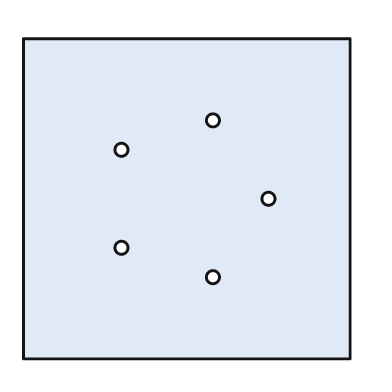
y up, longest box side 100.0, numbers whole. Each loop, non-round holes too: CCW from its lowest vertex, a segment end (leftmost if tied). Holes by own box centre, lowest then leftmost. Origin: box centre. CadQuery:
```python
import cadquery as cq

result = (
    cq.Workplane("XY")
    .moveTo(-50.0, -49.0)
    .lineTo(50.0, -49.0)
    .lineTo(50.0, 49.0)
    .lineTo(-50.0, 49.0)
    .close()
    .moveTo(8.0, -24.0)
    .circle(2.0)
    .moveTo(-20.0, -15.0)
    .circle(2.0)
    .moveTo(25.0, 0.0)
    .circle(2.0)
    .moveTo(-20.0, 15.0)
    .circle(2.0)
    .moveTo(8.0, 24.0)
    .circle(2.0)
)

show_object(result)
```